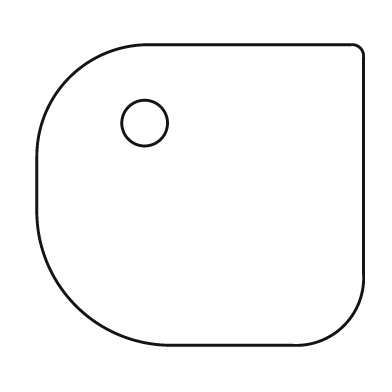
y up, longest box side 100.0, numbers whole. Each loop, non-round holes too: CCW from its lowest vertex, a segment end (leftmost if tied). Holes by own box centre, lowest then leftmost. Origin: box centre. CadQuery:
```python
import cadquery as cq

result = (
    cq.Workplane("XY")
    .moveTo(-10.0, -46.0)
    .lineTo(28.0, -46.0)
    .threePointArc((44.0, -40.0), (50.0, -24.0))
    .lineTo(50.0, 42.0)
    .threePointArc((49.0, 45.0), (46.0, 46.0))
    .lineTo(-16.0, 46.0)
    .threePointArc((-40.0, 36.0), (-50.0, 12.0))
    .lineTo(-50.0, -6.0)
    .threePointArc((-38.0, -34.0), (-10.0, -46.0))
    .close()
    .moveTo(-17.0, 22.0)
    .circle(7.0)
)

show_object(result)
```